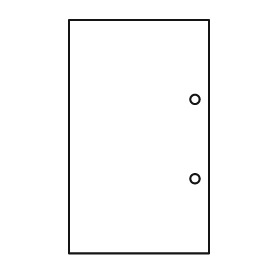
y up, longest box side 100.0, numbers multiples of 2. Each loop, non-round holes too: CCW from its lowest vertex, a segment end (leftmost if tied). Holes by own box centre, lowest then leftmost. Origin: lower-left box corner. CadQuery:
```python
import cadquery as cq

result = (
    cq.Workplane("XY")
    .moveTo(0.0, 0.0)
    .lineTo(60.0, 0.0)
    .lineTo(60.0, 100.0)
    .lineTo(0.0, 100.0)
    .close()
    .moveTo(54.0, 32.0)
    .circle(2.0)
    .moveTo(54.0, 66.0)
    .circle(2.0)
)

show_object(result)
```